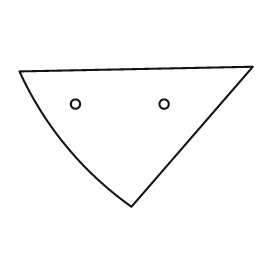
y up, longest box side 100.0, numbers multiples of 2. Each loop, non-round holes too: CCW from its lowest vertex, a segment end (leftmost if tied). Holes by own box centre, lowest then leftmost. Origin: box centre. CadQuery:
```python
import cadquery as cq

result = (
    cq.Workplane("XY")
    .moveTo(-2.0, -30.0)
    .lineTo(50.0, 30.0)
    .lineTo(-50.0, 28.0)
    .threePointArc((-30.0, -4.0), (-2.0, -30.0))
    .close()
    .moveTo(-26.0, 14.0)
    .circle(2.0)
    .moveTo(12.0, 14.0)
    .circle(2.0)
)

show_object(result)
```